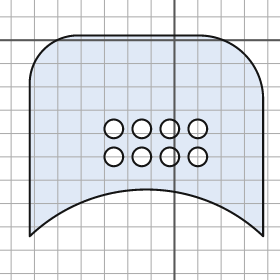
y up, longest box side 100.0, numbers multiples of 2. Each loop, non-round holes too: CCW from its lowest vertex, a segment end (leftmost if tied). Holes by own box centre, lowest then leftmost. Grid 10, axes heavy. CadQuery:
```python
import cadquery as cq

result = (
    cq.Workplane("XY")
    .moveTo(-62.0, -84.0)
    .threePointArc((-12.0, -64.0), (38.0, -84.0))
    .lineTo(38.0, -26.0)
    .threePointArc((30.0, -6.0), (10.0, 2.0))
    .lineTo(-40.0, 2.0)
    .threePointArc((-56.0, -4.0), (-62.0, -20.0))
    .close()
    .moveTo(-26.0, -50.0)
    .circle(4.0)
    .moveTo(-14.0, -50.0)
    .circle(4.0)
    .moveTo(-2.0, -50.0)
    .circle(4.0)
    .moveTo(10.0, -50.0)
    .circle(4.0)
    .moveTo(-26.0, -38.0)
    .circle(4.0)
    .moveTo(-14.0, -38.0)
    .circle(4.0)
    .moveTo(-2.0, -38.0)
    .circle(4.0)
    .moveTo(10.0, -38.0)
    .circle(4.0)
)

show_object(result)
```